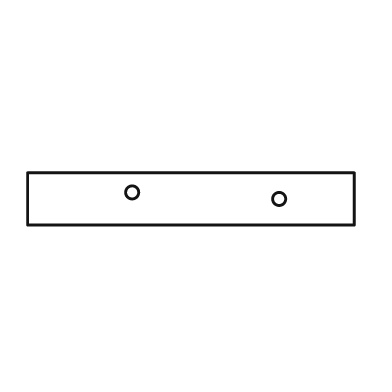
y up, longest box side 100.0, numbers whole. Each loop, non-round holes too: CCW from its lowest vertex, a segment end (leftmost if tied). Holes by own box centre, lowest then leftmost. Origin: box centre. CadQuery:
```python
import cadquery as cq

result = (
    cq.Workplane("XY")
    .moveTo(-50.0, -8.0)
    .lineTo(50.0, -8.0)
    .lineTo(50.0, 8.0)
    .lineTo(-50.0, 8.0)
    .close()
    .moveTo(27.0, 0.0)
    .circle(2.0)
    .moveTo(-18.0, 2.0)
    .circle(2.0)
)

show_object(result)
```